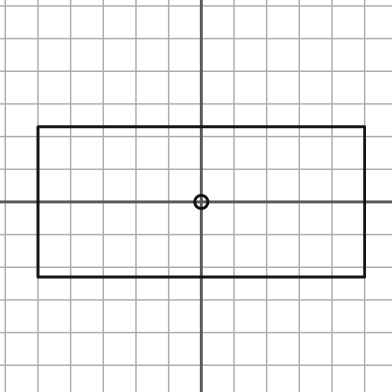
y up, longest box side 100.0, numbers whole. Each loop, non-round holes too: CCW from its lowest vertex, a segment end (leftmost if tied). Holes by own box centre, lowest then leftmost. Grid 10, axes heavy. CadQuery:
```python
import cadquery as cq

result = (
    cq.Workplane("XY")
    .moveTo(-50.0, -23.0)
    .lineTo(50.0, -23.0)
    .lineTo(50.0, 23.0)
    .lineTo(-50.0, 23.0)
    .close()
    .moveTo(0.0, 0.0)
    .circle(2.0)
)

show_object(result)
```